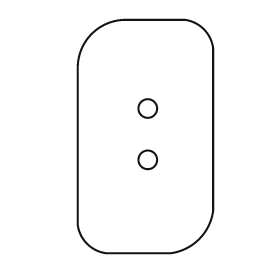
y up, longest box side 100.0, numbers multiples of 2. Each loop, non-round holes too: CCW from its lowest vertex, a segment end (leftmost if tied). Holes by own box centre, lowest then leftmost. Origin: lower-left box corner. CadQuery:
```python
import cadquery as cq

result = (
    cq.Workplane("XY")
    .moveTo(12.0, 0.0)
    .lineTo(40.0, 0.0)
    .threePointArc((52.0, 6.0), (58.0, 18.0))
    .lineTo(58.0, 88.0)
    .threePointArc((54.0, 96.0), (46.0, 100.0))
    .lineTo(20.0, 100.0)
    .threePointArc((6.0, 94.0), (0.0, 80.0))
    .lineTo(0.0, 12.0)
    .threePointArc((4.0, 4.0), (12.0, 0.0))
    .close()
    .moveTo(30.0, 40.0)
    .circle(4.0)
    .moveTo(30.0, 62.0)
    .circle(4.0)
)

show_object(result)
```